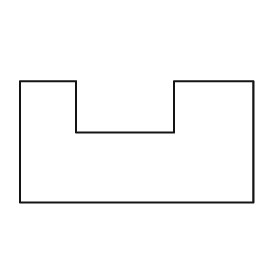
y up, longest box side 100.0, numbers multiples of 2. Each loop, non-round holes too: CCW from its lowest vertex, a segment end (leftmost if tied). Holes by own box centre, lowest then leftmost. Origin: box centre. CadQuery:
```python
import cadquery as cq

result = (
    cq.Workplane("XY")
    .moveTo(-50.0, -26.0)
    .lineTo(50.0, -26.0)
    .lineTo(50.0, 26.0)
    .lineTo(16.0, 26.0)
    .lineTo(16.0, 4.0)
    .lineTo(-26.0, 4.0)
    .lineTo(-26.0, 26.0)
    .lineTo(-50.0, 26.0)
    .close()
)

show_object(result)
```